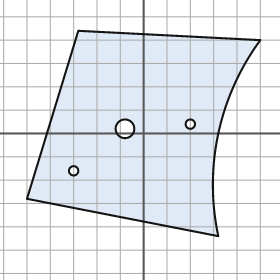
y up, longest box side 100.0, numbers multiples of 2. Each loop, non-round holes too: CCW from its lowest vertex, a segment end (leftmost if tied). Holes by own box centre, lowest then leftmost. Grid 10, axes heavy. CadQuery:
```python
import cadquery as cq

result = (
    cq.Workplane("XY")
    .moveTo(32.0, -44.0)
    .threePointArc((32.0, 0.0), (50.0, 40.0))
    .lineTo(-28.0, 44.0)
    .lineTo(-50.0, -28.0)
    .close()
    .moveTo(-30.0, -16.0)
    .circle(2.0)
    .moveTo(-8.0, 2.0)
    .circle(4.0)
    .moveTo(20.0, 4.0)
    .circle(2.0)
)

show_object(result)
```